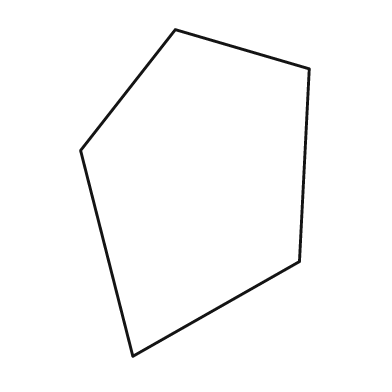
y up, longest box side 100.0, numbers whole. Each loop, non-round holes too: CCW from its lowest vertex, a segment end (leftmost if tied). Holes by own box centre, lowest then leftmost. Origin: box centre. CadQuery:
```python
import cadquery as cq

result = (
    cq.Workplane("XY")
    .moveTo(-19.0, -50.0)
    .lineTo(32.0, -21.0)
    .lineTo(35.0, 38.0)
    .lineTo(-6.0, 50.0)
    .lineTo(-35.0, 13.0)
    .close()
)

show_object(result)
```